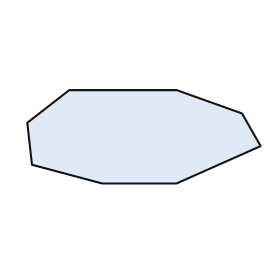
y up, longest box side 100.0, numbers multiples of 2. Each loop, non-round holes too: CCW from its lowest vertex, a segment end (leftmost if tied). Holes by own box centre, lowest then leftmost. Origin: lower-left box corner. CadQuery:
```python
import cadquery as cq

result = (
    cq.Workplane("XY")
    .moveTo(32.0, 0.0)
    .lineTo(64.0, 0.0)
    .lineTo(100.0, 16.0)
    .lineTo(92.0, 30.0)
    .lineTo(64.0, 40.0)
    .lineTo(18.0, 40.0)
    .lineTo(0.0, 26.0)
    .lineTo(2.0, 8.0)
    .close()
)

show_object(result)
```